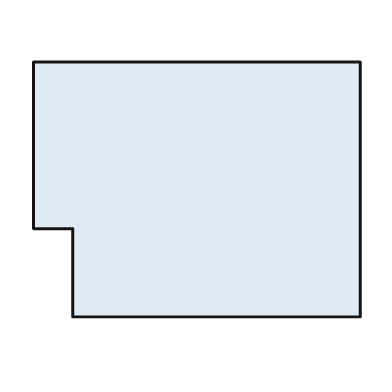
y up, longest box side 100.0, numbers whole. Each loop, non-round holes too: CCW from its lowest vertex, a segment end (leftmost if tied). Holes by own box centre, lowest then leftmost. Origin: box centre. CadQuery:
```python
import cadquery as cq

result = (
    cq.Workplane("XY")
    .moveTo(-38.0, -39.0)
    .lineTo(50.0, -39.0)
    .lineTo(50.0, 39.0)
    .lineTo(-50.0, 39.0)
    .lineTo(-50.0, -12.0)
    .lineTo(-38.0, -12.0)
    .close()
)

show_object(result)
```